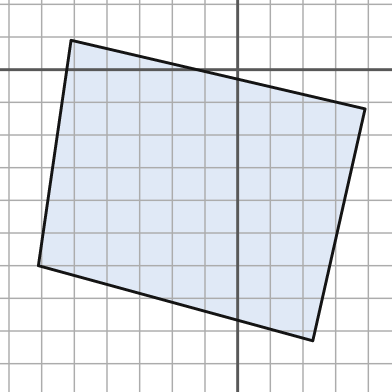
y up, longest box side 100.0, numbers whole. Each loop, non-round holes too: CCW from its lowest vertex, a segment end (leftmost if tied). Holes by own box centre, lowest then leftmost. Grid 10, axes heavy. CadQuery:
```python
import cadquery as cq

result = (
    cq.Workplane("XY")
    .moveTo(23.0, -83.0)
    .lineTo(39.0, -12.0)
    .lineTo(-51.0, 9.0)
    .lineTo(-61.0, -60.0)
    .close()
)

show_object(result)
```